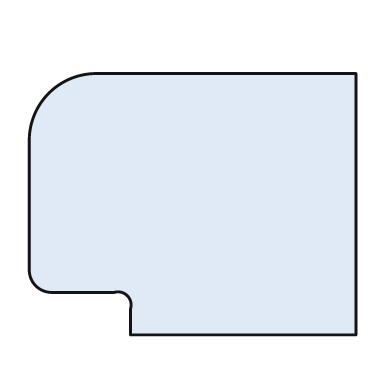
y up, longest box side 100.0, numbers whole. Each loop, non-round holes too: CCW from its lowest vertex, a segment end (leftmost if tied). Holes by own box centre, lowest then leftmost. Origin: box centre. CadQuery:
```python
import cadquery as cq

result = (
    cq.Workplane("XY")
    .moveTo(-19.0, -40.0)
    .lineTo(50.0, -40.0)
    .lineTo(50.0, 40.0)
    .lineTo(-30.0, 40.0)
    .threePointArc((-44.0, 34.0), (-50.0, 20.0))
    .lineTo(-50.0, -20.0)
    .threePointArc((-48.0, -25.0), (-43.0, -27.0))
    .lineTo(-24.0, -27.0)
    .threePointArc((-20.0, -28.0), (-19.0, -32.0))
    .close()
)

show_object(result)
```